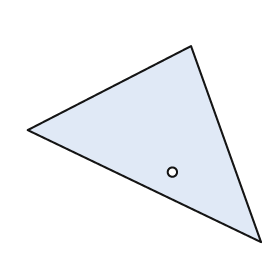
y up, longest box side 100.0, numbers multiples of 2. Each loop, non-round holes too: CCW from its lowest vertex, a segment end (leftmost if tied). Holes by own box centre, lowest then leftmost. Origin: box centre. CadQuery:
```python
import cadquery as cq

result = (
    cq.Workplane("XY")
    .moveTo(50.0, -42.0)
    .lineTo(20.0, 42.0)
    .lineTo(-50.0, 6.0)
    .close()
    .moveTo(12.0, -12.0)
    .circle(2.0)
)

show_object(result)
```